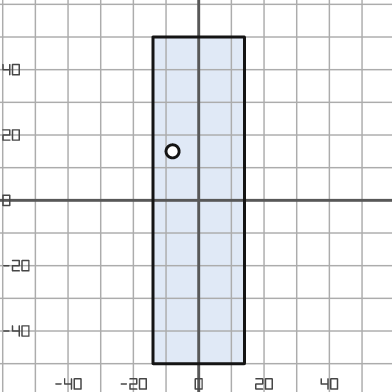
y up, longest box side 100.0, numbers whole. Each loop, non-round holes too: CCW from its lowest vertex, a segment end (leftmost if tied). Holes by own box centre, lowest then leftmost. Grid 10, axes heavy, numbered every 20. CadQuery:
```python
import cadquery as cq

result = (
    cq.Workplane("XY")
    .moveTo(-14.0, -50.0)
    .lineTo(14.0, -50.0)
    .lineTo(14.0, 50.0)
    .lineTo(-14.0, 50.0)
    .close()
    .moveTo(-8.0, 15.0)
    .circle(2.0)
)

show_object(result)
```